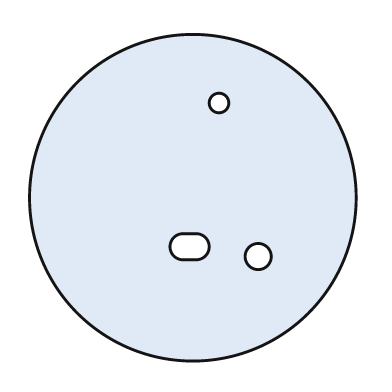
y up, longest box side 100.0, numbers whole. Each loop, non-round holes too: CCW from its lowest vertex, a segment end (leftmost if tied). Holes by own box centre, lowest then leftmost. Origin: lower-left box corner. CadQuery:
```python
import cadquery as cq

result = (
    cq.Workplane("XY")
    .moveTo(50.0, 50.0)
    .circle(50.0)
    .moveTo(70.0, 32.0)
    .circle(4.0)
    .moveTo(47.0, 31.0)
    .lineTo(51.0, 31.0)
    .threePointArc((55.0, 35.0), (51.0, 39.0))
    .lineTo(47.0, 39.0)
    .threePointArc((43.0, 35.0), (47.0, 31.0))
    .close()
    .moveTo(58.0, 79.0)
    .circle(3.0)
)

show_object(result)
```